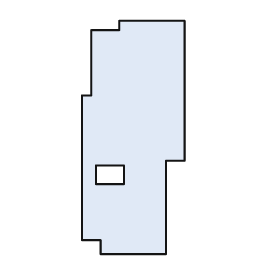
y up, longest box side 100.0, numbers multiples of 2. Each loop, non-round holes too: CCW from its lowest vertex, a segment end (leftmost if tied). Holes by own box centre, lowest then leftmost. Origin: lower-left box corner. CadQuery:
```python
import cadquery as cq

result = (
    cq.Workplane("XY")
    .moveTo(8.0, 0.0)
    .lineTo(36.0, 0.0)
    .lineTo(36.0, 40.0)
    .lineTo(44.0, 40.0)
    .lineTo(44.0, 100.0)
    .lineTo(16.0, 100.0)
    .lineTo(16.0, 96.0)
    .lineTo(4.0, 96.0)
    .lineTo(4.0, 68.0)
    .lineTo(0.0, 68.0)
    .lineTo(0.0, 6.0)
    .lineTo(8.0, 6.0)
    .close()
    .moveTo(6.0, 30.0)
    .lineTo(18.0, 30.0)
    .lineTo(18.0, 38.0)
    .lineTo(6.0, 38.0)
    .close()
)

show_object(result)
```